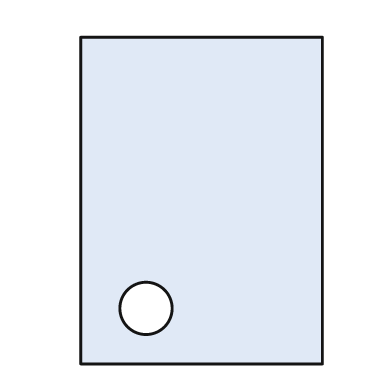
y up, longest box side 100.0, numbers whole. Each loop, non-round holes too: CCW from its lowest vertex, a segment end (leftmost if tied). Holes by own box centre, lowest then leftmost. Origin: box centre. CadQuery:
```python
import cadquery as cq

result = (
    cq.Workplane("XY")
    .moveTo(-37.0, -50.0)
    .lineTo(37.0, -50.0)
    .lineTo(37.0, 50.0)
    .lineTo(-37.0, 50.0)
    .close()
    .moveTo(-17.0, -33.0)
    .circle(8.0)
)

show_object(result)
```